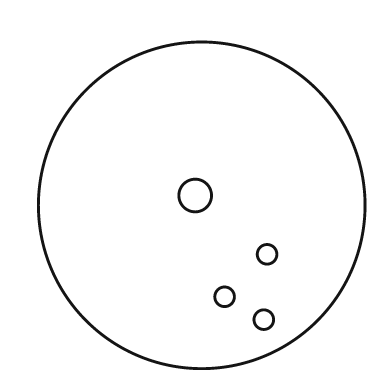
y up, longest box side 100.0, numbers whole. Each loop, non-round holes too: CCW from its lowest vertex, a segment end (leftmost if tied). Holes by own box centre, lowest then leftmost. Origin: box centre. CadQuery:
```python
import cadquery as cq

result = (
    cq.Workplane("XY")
    .moveTo(0.0, 0.0)
    .circle(50.0)
    .moveTo(19.0, -35.0)
    .circle(3.0)
    .moveTo(7.0, -28.0)
    .circle(3.0)
    .moveTo(20.0, -15.0)
    .circle(3.0)
    .moveTo(-2.0, 3.0)
    .circle(5.0)
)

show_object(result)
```